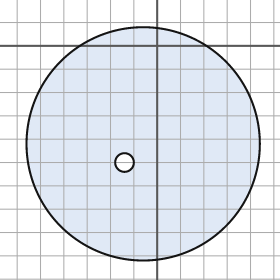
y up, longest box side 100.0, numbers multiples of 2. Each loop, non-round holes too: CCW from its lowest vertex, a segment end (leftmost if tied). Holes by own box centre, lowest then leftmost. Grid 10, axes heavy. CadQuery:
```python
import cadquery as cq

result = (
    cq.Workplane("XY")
    .moveTo(-6.0, -42.0)
    .circle(50.0)
    .moveTo(-14.0, -50.0)
    .circle(4.0)
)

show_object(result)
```